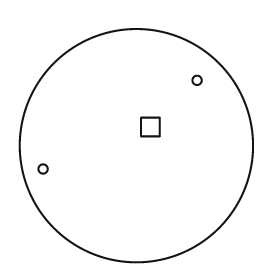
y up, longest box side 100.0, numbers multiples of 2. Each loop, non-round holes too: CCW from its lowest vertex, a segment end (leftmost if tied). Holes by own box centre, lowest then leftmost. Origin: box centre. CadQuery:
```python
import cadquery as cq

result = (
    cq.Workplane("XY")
    .moveTo(0.0, 0.0)
    .circle(50.0)
    .moveTo(-40.0, -10.0)
    .circle(2.0)
    .moveTo(2.0, 4.0)
    .lineTo(10.0, 4.0)
    .lineTo(10.0, 12.0)
    .lineTo(2.0, 12.0)
    .close()
    .moveTo(26.0, 28.0)
    .circle(2.0)
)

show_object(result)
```